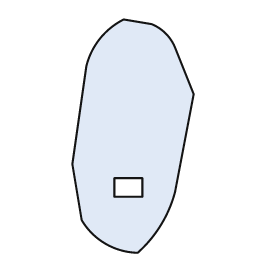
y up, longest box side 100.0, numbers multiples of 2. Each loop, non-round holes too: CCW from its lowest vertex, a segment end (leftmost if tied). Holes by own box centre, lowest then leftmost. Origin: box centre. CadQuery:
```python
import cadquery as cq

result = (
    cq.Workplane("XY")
    .moveTo(2.0, -50.0)
    .threePointArc((12.0, -38.0), (18.0, -24.0))
    .lineTo(26.0, 18.0)
    .lineTo(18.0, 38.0)
    .threePointArc((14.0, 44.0), (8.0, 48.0))
    .lineTo(-4.0, 50.0)
    .threePointArc((-14.0, 42.0), (-20.0, 30.0))
    .lineTo(-26.0, -12.0)
    .lineTo(-22.0, -36.0)
    .threePointArc((-12.0, -46.0), (2.0, -50.0))
    .close()
    .moveTo(-8.0, -26.0)
    .lineTo(4.0, -26.0)
    .lineTo(4.0, -18.0)
    .lineTo(-8.0, -18.0)
    .close()
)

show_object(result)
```